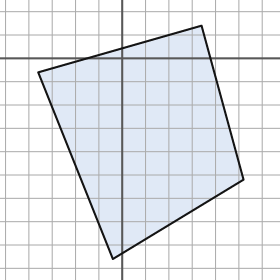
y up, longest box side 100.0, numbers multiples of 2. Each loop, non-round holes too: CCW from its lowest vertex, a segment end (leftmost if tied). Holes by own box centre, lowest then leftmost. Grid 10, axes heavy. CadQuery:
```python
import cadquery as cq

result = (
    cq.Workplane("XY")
    .moveTo(-4.0, -86.0)
    .lineTo(52.0, -52.0)
    .lineTo(34.0, 14.0)
    .lineTo(-36.0, -6.0)
    .close()
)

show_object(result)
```